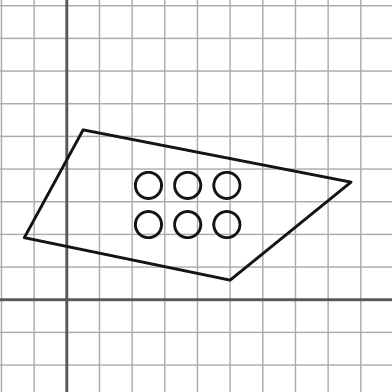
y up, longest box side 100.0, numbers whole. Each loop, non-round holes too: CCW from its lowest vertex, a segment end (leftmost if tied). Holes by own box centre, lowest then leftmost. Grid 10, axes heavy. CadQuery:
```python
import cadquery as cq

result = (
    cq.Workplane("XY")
    .moveTo(50.0, 6.0)
    .lineTo(87.0, 36.0)
    .lineTo(5.0, 52.0)
    .lineTo(-13.0, 19.0)
    .close()
    .moveTo(25.0, 23.0)
    .circle(4.0)
    .moveTo(37.0, 23.0)
    .circle(4.0)
    .moveTo(49.0, 23.0)
    .circle(4.0)
    .moveTo(25.0, 35.0)
    .circle(4.0)
    .moveTo(37.0, 35.0)
    .circle(4.0)
    .moveTo(49.0, 35.0)
    .circle(4.0)
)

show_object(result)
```